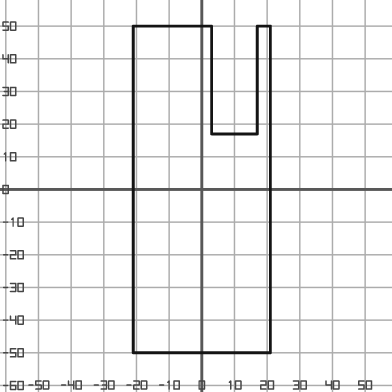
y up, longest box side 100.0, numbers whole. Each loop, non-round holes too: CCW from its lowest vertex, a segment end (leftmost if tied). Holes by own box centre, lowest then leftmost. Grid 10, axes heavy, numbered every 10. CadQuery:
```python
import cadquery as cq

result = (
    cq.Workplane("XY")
    .moveTo(-21.0, -50.0)
    .lineTo(21.0, -50.0)
    .lineTo(21.0, 50.0)
    .lineTo(17.0, 50.0)
    .lineTo(17.0, 17.0)
    .lineTo(3.0, 17.0)
    .lineTo(3.0, 50.0)
    .lineTo(-21.0, 50.0)
    .close()
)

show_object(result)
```